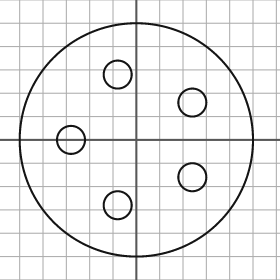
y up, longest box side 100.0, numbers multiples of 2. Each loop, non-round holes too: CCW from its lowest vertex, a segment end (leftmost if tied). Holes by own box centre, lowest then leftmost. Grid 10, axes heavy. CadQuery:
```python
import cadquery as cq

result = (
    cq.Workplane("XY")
    .moveTo(0.0, 0.0)
    .circle(50.0)
    .moveTo(-8.0, -28.0)
    .circle(6.0)
    .moveTo(24.0, -16.0)
    .circle(6.0)
    .moveTo(-28.0, 0.0)
    .circle(6.0)
    .moveTo(24.0, 16.0)
    .circle(6.0)
    .moveTo(-8.0, 28.0)
    .circle(6.0)
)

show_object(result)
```